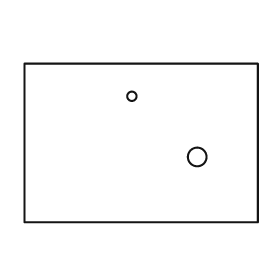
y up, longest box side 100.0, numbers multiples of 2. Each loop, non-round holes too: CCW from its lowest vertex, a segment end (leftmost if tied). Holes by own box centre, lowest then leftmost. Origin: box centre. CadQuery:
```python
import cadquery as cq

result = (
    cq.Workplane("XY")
    .moveTo(-50.0, -34.0)
    .lineTo(50.0, -34.0)
    .lineTo(50.0, 34.0)
    .lineTo(-50.0, 34.0)
    .close()
    .moveTo(24.0, -6.0)
    .circle(4.0)
    .moveTo(-4.0, 20.0)
    .circle(2.0)
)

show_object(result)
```